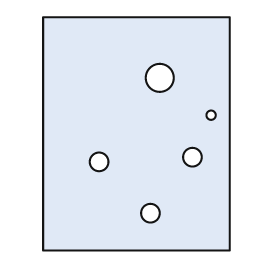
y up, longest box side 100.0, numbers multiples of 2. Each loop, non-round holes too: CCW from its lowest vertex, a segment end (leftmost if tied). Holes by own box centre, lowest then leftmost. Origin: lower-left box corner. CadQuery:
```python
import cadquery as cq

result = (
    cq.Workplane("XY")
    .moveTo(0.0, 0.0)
    .lineTo(80.0, 0.0)
    .lineTo(80.0, 100.0)
    .lineTo(0.0, 100.0)
    .close()
    .moveTo(46.0, 16.0)
    .circle(4.0)
    .moveTo(24.0, 38.0)
    .circle(4.0)
    .moveTo(64.0, 40.0)
    .circle(4.0)
    .moveTo(72.0, 58.0)
    .circle(2.0)
    .moveTo(50.0, 74.0)
    .circle(6.0)
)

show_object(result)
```